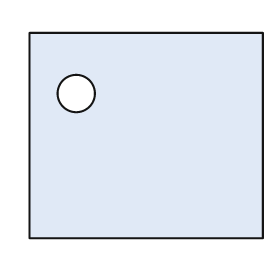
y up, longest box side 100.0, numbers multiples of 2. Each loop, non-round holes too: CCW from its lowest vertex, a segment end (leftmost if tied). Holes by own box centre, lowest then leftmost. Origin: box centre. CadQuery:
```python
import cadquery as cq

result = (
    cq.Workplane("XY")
    .moveTo(-50.0, -44.0)
    .lineTo(50.0, -44.0)
    .lineTo(50.0, 44.0)
    .lineTo(-50.0, 44.0)
    .close()
    .moveTo(-30.0, 18.0)
    .circle(8.0)
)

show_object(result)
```